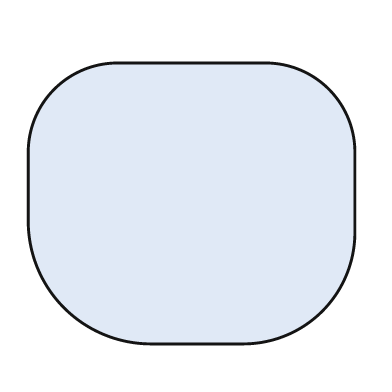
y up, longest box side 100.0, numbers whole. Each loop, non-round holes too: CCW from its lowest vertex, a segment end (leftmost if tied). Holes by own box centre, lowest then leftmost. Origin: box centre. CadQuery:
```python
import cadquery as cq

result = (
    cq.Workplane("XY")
    .moveTo(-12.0, -43.0)
    .lineTo(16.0, -43.0)
    .threePointArc((40.0, -33.0), (50.0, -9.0))
    .lineTo(50.0, 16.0)
    .threePointArc((42.0, 35.0), (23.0, 43.0))
    .lineTo(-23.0, 43.0)
    .threePointArc((-42.0, 35.0), (-50.0, 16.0))
    .lineTo(-50.0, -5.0)
    .threePointArc((-39.0, -32.0), (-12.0, -43.0))
    .close()
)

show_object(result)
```